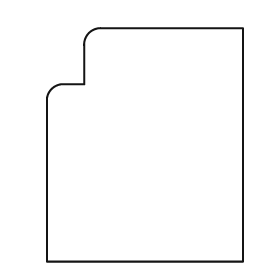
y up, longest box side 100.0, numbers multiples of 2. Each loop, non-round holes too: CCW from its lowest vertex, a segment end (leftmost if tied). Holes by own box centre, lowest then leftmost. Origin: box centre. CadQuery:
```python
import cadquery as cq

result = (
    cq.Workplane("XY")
    .moveTo(-42.0, -50.0)
    .lineTo(42.0, -50.0)
    .lineTo(42.0, 50.0)
    .lineTo(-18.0, 50.0)
    .threePointArc((-24.0, 48.0), (-26.0, 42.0))
    .lineTo(-26.0, 26.0)
    .lineTo(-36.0, 26.0)
    .threePointArc((-40.0, 24.0), (-42.0, 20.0))
    .close()
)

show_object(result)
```